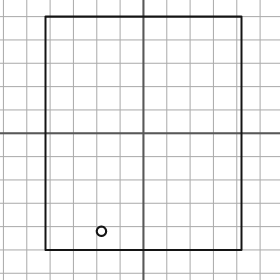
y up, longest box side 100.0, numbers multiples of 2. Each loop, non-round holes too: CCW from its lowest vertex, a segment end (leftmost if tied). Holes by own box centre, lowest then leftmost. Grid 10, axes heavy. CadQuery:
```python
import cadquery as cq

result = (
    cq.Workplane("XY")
    .moveTo(-42.0, -50.0)
    .lineTo(42.0, -50.0)
    .lineTo(42.0, 50.0)
    .lineTo(-42.0, 50.0)
    .close()
    .moveTo(-18.0, -42.0)
    .circle(2.0)
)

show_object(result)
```